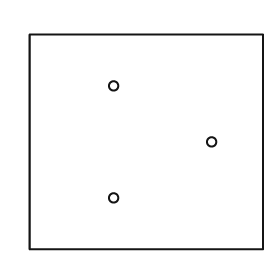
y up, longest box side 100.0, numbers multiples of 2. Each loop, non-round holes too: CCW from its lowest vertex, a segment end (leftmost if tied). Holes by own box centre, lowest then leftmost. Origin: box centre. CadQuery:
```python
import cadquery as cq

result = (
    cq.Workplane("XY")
    .moveTo(-50.0, -46.0)
    .lineTo(50.0, -46.0)
    .lineTo(50.0, 46.0)
    .lineTo(-50.0, 46.0)
    .close()
    .moveTo(-14.0, -24.0)
    .circle(2.0)
    .moveTo(28.0, 0.0)
    .circle(2.0)
    .moveTo(-14.0, 24.0)
    .circle(2.0)
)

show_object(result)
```